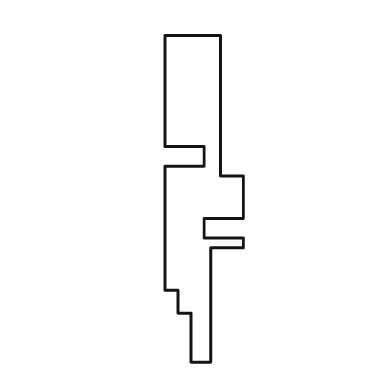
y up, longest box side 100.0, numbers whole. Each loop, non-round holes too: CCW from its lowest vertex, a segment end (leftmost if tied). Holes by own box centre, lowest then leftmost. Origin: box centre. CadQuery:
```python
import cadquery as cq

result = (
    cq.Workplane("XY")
    .moveTo(-4.0, -50.0)
    .lineTo(2.0, -50.0)
    .lineTo(2.0, -15.0)
    .lineTo(12.0, -15.0)
    .lineTo(12.0, -12.0)
    .lineTo(0.0, -12.0)
    .lineTo(0.0, -6.0)
    .lineTo(12.0, -6.0)
    .lineTo(12.0, 7.0)
    .lineTo(5.0, 7.0)
    .lineTo(5.0, 50.0)
    .lineTo(-12.0, 50.0)
    .lineTo(-12.0, 16.0)
    .lineTo(0.0, 16.0)
    .lineTo(0.0, 10.0)
    .lineTo(-12.0, 10.0)
    .lineTo(-12.0, -28.0)
    .lineTo(-8.0, -28.0)
    .lineTo(-8.0, -35.0)
    .lineTo(-4.0, -35.0)
    .close()
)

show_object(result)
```